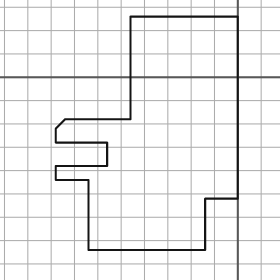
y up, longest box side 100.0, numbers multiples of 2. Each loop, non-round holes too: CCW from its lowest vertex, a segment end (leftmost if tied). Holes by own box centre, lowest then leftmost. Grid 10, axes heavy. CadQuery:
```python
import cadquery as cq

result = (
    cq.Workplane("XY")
    .moveTo(-64.0, -74.0)
    .lineTo(-14.0, -74.0)
    .lineTo(-14.0, -52.0)
    .lineTo(0.0, -52.0)
    .lineTo(0.0, 26.0)
    .lineTo(-46.0, 26.0)
    .lineTo(-46.0, -18.0)
    .lineTo(-74.0, -18.0)
    .lineTo(-78.0, -22.0)
    .lineTo(-78.0, -28.0)
    .lineTo(-56.0, -28.0)
    .lineTo(-56.0, -38.0)
    .lineTo(-78.0, -38.0)
    .lineTo(-78.0, -44.0)
    .lineTo(-64.0, -44.0)
    .close()
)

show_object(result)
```